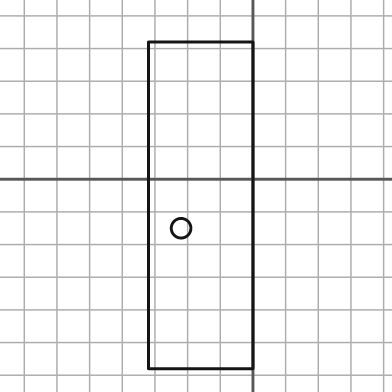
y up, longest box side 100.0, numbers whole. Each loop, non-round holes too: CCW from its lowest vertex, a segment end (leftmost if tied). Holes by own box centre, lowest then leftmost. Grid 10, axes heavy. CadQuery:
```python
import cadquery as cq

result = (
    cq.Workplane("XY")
    .moveTo(-32.0, -58.0)
    .lineTo(0.0, -58.0)
    .lineTo(0.0, 42.0)
    .lineTo(-32.0, 42.0)
    .close()
    .moveTo(-22.0, -15.0)
    .circle(3.0)
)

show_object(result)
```